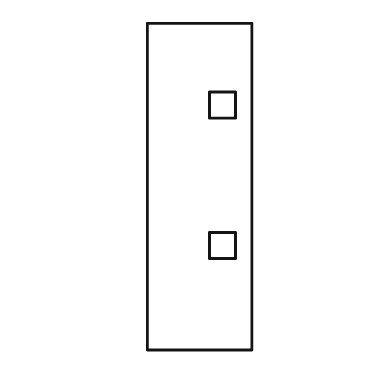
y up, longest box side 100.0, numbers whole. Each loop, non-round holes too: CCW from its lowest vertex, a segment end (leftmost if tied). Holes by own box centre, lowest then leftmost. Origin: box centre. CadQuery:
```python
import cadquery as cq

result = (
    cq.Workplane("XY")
    .moveTo(-16.0, -50.0)
    .lineTo(16.0, -50.0)
    .lineTo(16.0, 50.0)
    .lineTo(-16.0, 50.0)
    .close()
    .moveTo(3.0, -22.0)
    .lineTo(11.0, -22.0)
    .lineTo(11.0, -14.0)
    .lineTo(3.0, -14.0)
    .close()
    .moveTo(3.0, 21.0)
    .lineTo(11.0, 21.0)
    .lineTo(11.0, 29.0)
    .lineTo(3.0, 29.0)
    .close()
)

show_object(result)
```